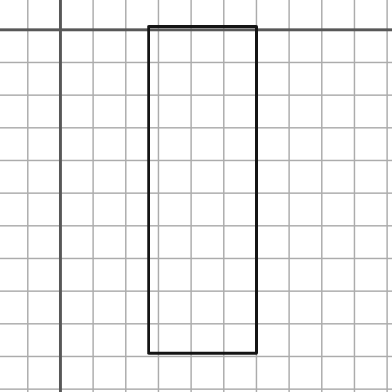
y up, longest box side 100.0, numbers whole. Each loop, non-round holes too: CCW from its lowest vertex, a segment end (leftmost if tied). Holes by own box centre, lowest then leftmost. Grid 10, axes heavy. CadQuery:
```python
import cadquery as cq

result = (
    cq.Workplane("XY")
    .moveTo(27.0, -99.0)
    .lineTo(60.0, -99.0)
    .lineTo(60.0, 1.0)
    .lineTo(27.0, 1.0)
    .close()
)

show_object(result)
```